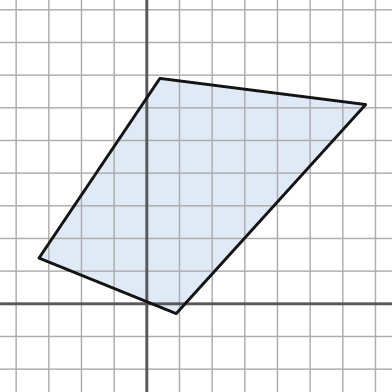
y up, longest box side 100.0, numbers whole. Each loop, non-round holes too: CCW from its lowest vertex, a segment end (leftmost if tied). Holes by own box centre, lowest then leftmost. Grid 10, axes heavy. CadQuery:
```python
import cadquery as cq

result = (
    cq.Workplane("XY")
    .moveTo(9.0, -3.0)
    .lineTo(67.0, 61.0)
    .lineTo(4.0, 69.0)
    .lineTo(-33.0, 14.0)
    .close()
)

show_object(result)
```